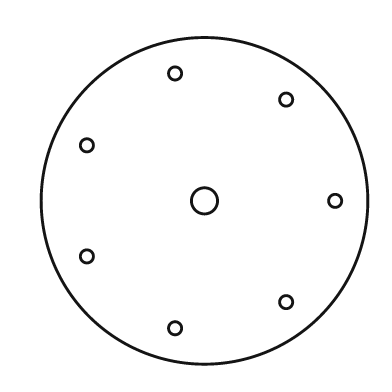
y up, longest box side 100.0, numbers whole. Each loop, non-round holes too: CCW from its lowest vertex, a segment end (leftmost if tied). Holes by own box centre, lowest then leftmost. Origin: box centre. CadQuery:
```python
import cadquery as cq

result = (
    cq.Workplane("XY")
    .moveTo(0.0, 0.0)
    .circle(50.0)
    .moveTo(-9.0, -39.0)
    .circle(2.0)
    .moveTo(25.0, -31.0)
    .circle(2.0)
    .moveTo(-36.0, -17.0)
    .circle(2.0)
    .moveTo(0.0, 0.0)
    .circle(4.0)
    .moveTo(40.0, 0.0)
    .circle(2.0)
    .moveTo(-36.0, 17.0)
    .circle(2.0)
    .moveTo(25.0, 31.0)
    .circle(2.0)
    .moveTo(-9.0, 39.0)
    .circle(2.0)
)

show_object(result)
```